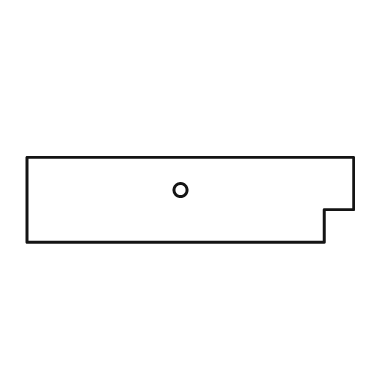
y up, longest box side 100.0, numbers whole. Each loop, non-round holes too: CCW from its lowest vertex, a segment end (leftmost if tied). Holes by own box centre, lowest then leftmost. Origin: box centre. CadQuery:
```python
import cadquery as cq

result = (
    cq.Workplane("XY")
    .moveTo(-50.0, -13.0)
    .lineTo(41.0, -13.0)
    .lineTo(41.0, -3.0)
    .lineTo(50.0, -3.0)
    .lineTo(50.0, 13.0)
    .lineTo(-50.0, 13.0)
    .close()
    .moveTo(-3.0, 3.0)
    .circle(2.0)
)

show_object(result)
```